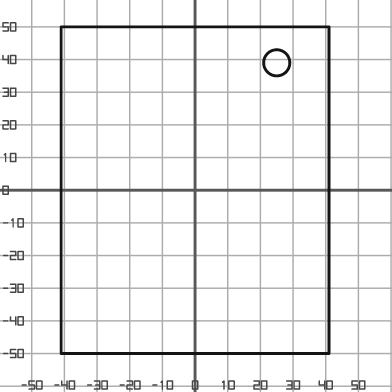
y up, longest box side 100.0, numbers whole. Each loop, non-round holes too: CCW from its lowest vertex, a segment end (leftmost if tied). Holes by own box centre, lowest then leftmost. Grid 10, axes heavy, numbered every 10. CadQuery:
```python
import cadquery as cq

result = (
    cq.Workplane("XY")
    .moveTo(-41.0, -50.0)
    .lineTo(41.0, -50.0)
    .lineTo(41.0, 50.0)
    .lineTo(-41.0, 50.0)
    .close()
    .moveTo(25.0, 39.0)
    .circle(4.0)
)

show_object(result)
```